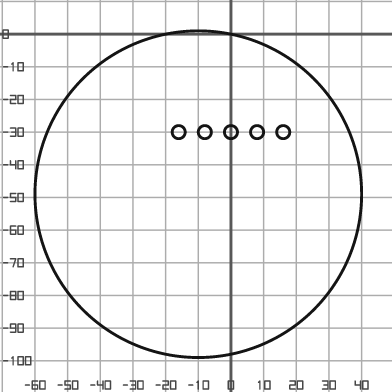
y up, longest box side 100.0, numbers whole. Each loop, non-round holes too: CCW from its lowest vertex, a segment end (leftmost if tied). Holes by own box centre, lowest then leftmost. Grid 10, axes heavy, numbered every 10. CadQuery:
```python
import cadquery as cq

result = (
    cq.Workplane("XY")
    .moveTo(-10.0, -49.0)
    .circle(50.0)
    .moveTo(-16.0, -30.0)
    .circle(2.0)
    .moveTo(-8.0, -30.0)
    .circle(2.0)
    .moveTo(0.0, -30.0)
    .circle(2.0)
    .moveTo(8.0, -30.0)
    .circle(2.0)
    .moveTo(16.0, -30.0)
    .circle(2.0)
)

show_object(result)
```